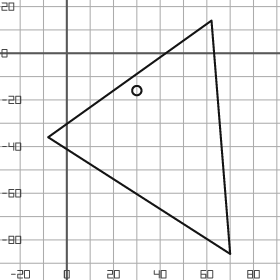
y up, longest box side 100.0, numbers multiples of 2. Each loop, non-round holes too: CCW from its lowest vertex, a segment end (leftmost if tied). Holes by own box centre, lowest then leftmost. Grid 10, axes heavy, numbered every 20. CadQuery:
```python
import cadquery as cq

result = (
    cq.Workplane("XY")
    .moveTo(70.0, -86.0)
    .lineTo(62.0, 14.0)
    .lineTo(-8.0, -36.0)
    .close()
    .moveTo(30.0, -16.0)
    .circle(2.0)
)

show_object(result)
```